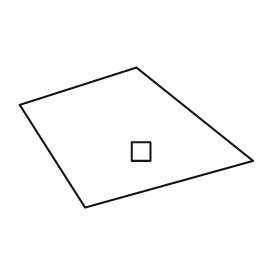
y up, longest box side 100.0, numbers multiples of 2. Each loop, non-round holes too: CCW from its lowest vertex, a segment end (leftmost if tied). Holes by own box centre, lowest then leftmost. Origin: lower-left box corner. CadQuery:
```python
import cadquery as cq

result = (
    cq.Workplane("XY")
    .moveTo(28.0, 0.0)
    .lineTo(100.0, 20.0)
    .lineTo(50.0, 60.0)
    .lineTo(0.0, 44.0)
    .close()
    .moveTo(48.0, 20.0)
    .lineTo(56.0, 20.0)
    .lineTo(56.0, 28.0)
    .lineTo(48.0, 28.0)
    .close()
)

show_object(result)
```